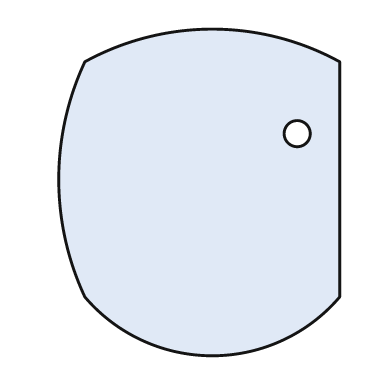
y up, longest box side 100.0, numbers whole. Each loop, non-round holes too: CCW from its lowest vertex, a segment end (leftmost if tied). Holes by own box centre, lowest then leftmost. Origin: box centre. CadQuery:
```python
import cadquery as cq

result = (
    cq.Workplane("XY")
    .moveTo(-35.0, -32.0)
    .threePointArc((4.0, -50.0), (43.0, -32.0))
    .lineTo(43.0, 40.0)
    .threePointArc((4.0, 50.0), (-35.0, 40.0))
    .threePointArc((-43.0, 4.0), (-35.0, -32.0))
    .close()
    .moveTo(30.0, 18.0)
    .circle(4.0)
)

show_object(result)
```